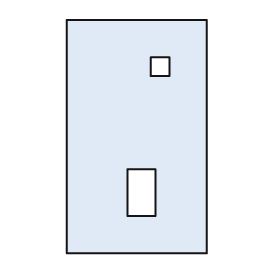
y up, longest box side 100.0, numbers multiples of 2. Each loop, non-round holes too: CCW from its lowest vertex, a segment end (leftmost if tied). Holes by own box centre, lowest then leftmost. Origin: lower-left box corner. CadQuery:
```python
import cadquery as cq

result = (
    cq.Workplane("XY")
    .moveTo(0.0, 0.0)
    .lineTo(60.0, 0.0)
    .lineTo(60.0, 100.0)
    .lineTo(0.0, 100.0)
    .close()
    .moveTo(26.0, 16.0)
    .lineTo(38.0, 16.0)
    .lineTo(38.0, 36.0)
    .lineTo(26.0, 36.0)
    .close()
    .moveTo(36.0, 76.0)
    .lineTo(44.0, 76.0)
    .lineTo(44.0, 84.0)
    .lineTo(36.0, 84.0)
    .close()
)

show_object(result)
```